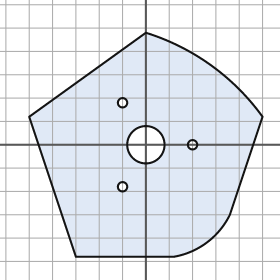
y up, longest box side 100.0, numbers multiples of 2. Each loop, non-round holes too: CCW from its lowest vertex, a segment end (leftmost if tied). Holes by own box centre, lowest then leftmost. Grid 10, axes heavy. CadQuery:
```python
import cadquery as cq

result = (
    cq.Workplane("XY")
    .moveTo(-30.0, -48.0)
    .lineTo(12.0, -48.0)
    .threePointArc((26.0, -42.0), (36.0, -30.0))
    .lineTo(50.0, 12.0)
    .threePointArc((28.0, 34.0), (0.0, 48.0))
    .lineTo(-50.0, 12.0)
    .close()
    .moveTo(-10.0, -18.0)
    .circle(2.0)
    .moveTo(0.0, 0.0)
    .circle(8.0)
    .moveTo(20.0, 0.0)
    .circle(2.0)
    .moveTo(-10.0, 18.0)
    .circle(2.0)
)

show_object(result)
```